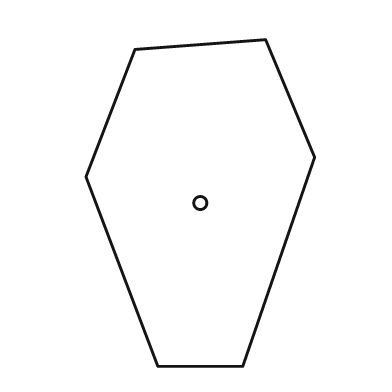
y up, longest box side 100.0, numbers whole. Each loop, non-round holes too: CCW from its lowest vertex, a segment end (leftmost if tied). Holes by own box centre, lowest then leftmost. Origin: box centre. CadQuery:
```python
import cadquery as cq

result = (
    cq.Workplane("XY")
    .moveTo(-13.0, -50.0)
    .lineTo(13.0, -50.0)
    .lineTo(35.0, 14.0)
    .lineTo(20.0, 50.0)
    .lineTo(-20.0, 47.0)
    .lineTo(-35.0, 8.0)
    .close()
    .moveTo(0.0, 0.0)
    .circle(2.0)
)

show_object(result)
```